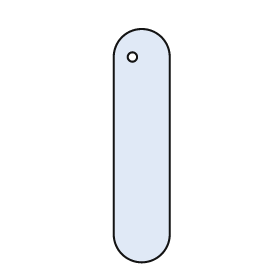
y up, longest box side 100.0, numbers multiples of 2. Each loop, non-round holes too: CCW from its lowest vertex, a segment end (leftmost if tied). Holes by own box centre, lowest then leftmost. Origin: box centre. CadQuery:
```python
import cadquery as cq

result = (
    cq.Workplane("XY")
    .moveTo(-12.0, -38.0)
    .threePointArc((0.0, -50.0), (12.0, -38.0))
    .lineTo(12.0, 38.0)
    .threePointArc((0.0, 50.0), (-12.0, 38.0))
    .close()
    .moveTo(-4.0, 38.0)
    .circle(2.0)
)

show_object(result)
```